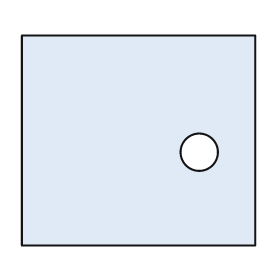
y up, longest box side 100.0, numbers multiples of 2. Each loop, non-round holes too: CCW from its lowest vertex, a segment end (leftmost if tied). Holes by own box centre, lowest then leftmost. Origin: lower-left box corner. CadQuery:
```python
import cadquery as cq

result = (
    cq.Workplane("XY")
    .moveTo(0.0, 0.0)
    .lineTo(100.0, 0.0)
    .lineTo(100.0, 90.0)
    .lineTo(0.0, 90.0)
    .close()
    .moveTo(76.0, 40.0)
    .circle(8.0)
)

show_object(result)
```